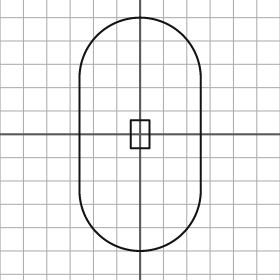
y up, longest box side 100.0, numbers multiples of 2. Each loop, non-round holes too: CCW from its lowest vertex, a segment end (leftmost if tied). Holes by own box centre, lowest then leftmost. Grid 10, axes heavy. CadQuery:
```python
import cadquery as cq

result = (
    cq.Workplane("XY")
    .moveTo(-26.0, -24.0)
    .threePointArc((0.0, -50.0), (26.0, -24.0))
    .lineTo(26.0, 24.0)
    .threePointArc((0.0, 50.0), (-26.0, 24.0))
    .close()
    .moveTo(-4.0, -6.0)
    .lineTo(4.0, -6.0)
    .lineTo(4.0, 6.0)
    .lineTo(-4.0, 6.0)
    .close()
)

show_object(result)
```